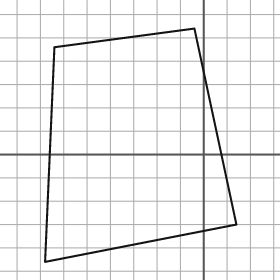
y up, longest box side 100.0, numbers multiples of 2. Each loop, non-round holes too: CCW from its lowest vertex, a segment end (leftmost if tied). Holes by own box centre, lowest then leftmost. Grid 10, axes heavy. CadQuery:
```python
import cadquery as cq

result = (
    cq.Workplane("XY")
    .moveTo(-68.0, -46.0)
    .lineTo(14.0, -30.0)
    .lineTo(-4.0, 54.0)
    .lineTo(-64.0, 46.0)
    .close()
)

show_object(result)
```